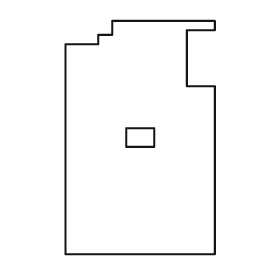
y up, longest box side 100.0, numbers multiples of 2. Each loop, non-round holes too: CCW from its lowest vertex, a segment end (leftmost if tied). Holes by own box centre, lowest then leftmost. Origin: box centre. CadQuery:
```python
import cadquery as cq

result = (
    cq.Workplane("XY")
    .moveTo(-32.0, -50.0)
    .lineTo(32.0, -50.0)
    .lineTo(32.0, 22.0)
    .lineTo(20.0, 22.0)
    .lineTo(20.0, 46.0)
    .lineTo(32.0, 46.0)
    .lineTo(32.0, 50.0)
    .lineTo(-12.0, 50.0)
    .lineTo(-12.0, 44.0)
    .lineTo(-18.0, 44.0)
    .lineTo(-18.0, 40.0)
    .lineTo(-32.0, 40.0)
    .close()
    .moveTo(-6.0, -4.0)
    .lineTo(6.0, -4.0)
    .lineTo(6.0, 4.0)
    .lineTo(-6.0, 4.0)
    .close()
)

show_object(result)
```